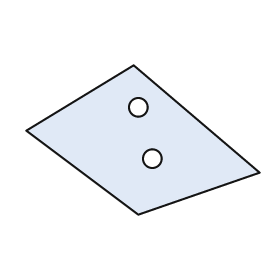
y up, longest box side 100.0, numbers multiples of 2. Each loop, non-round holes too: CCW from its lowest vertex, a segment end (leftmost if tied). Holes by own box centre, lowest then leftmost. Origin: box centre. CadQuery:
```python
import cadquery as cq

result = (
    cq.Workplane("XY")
    .moveTo(-2.0, -32.0)
    .lineTo(50.0, -14.0)
    .lineTo(-4.0, 32.0)
    .lineTo(-50.0, 4.0)
    .close()
    .moveTo(4.0, -8.0)
    .circle(4.0)
    .moveTo(-2.0, 14.0)
    .circle(4.0)
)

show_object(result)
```